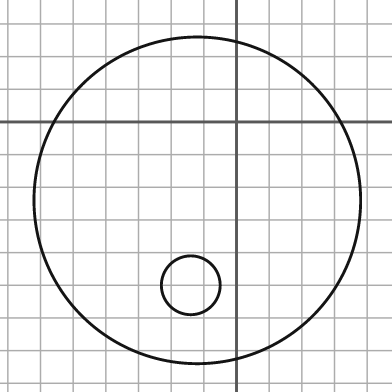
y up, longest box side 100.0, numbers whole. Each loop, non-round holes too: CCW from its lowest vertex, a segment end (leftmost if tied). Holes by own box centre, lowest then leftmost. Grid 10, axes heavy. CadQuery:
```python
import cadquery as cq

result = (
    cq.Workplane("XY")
    .moveTo(-12.0, -24.0)
    .circle(50.0)
    .moveTo(-14.0, -50.0)
    .circle(9.0)
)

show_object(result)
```